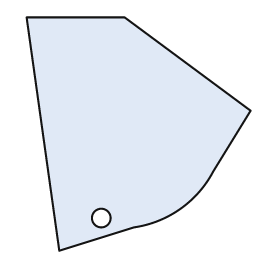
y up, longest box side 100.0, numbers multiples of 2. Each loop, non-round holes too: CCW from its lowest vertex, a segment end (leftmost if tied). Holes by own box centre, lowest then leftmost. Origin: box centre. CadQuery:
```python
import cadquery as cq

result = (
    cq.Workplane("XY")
    .moveTo(-34.0, -50.0)
    .lineTo(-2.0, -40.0)
    .threePointArc((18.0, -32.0), (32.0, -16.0))
    .lineTo(48.0, 10.0)
    .lineTo(-6.0, 50.0)
    .lineTo(-48.0, 50.0)
    .close()
    .moveTo(-16.0, -36.0)
    .circle(4.0)
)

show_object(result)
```